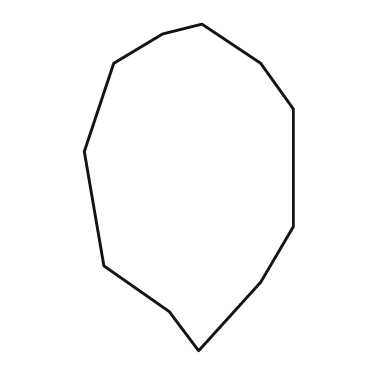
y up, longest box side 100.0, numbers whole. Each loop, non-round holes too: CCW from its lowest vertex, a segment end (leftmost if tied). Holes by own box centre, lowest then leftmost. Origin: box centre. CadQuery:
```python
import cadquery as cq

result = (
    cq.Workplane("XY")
    .moveTo(3.0, -50.0)
    .lineTo(22.0, -29.0)
    .lineTo(32.0, -12.0)
    .lineTo(32.0, 24.0)
    .lineTo(22.0, 38.0)
    .lineTo(4.0, 50.0)
    .lineTo(-8.0, 47.0)
    .lineTo(-23.0, 38.0)
    .lineTo(-32.0, 11.0)
    .lineTo(-26.0, -24.0)
    .lineTo(-6.0, -38.0)
    .close()
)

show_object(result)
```